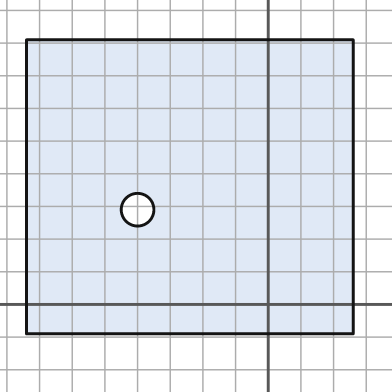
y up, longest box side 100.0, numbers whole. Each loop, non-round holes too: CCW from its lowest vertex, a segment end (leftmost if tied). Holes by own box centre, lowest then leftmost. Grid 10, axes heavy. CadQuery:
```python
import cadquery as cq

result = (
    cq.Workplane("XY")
    .moveTo(-74.0, -9.0)
    .lineTo(26.0, -9.0)
    .lineTo(26.0, 81.0)
    .lineTo(-74.0, 81.0)
    .close()
    .moveTo(-40.0, 29.0)
    .circle(5.0)
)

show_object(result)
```